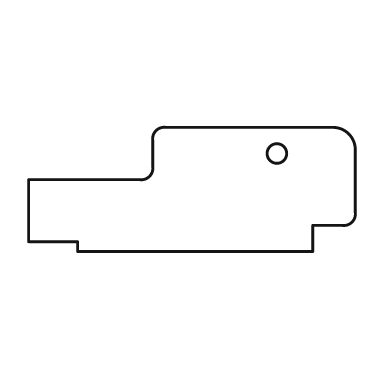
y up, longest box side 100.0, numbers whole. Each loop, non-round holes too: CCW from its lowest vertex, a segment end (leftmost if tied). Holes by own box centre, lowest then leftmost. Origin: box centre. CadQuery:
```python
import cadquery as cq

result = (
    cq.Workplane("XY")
    .moveTo(-35.0, -19.0)
    .lineTo(37.0, -19.0)
    .lineTo(37.0, -11.0)
    .lineTo(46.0, -11.0)
    .threePointArc((49.0, -10.0), (50.0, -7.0))
    .lineTo(50.0, 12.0)
    .threePointArc((48.0, 17.0), (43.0, 19.0))
    .lineTo(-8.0, 19.0)
    .threePointArc((-11.0, 18.0), (-12.0, 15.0))
    .lineTo(-12.0, 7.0)
    .threePointArc((-13.0, 4.0), (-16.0, 3.0))
    .lineTo(-50.0, 3.0)
    .lineTo(-50.0, -16.0)
    .lineTo(-35.0, -16.0)
    .close()
    .moveTo(26.0, 11.0)
    .circle(3.0)
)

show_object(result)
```